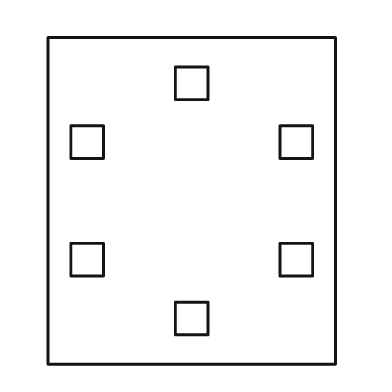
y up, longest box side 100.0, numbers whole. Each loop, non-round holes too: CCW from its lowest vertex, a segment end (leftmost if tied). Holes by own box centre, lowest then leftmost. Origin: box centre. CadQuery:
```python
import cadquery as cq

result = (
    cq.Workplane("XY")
    .moveTo(-44.0, -50.0)
    .lineTo(44.0, -50.0)
    .lineTo(44.0, 50.0)
    .lineTo(-44.0, 50.0)
    .close()
    .moveTo(-5.0, -41.0)
    .lineTo(5.0, -41.0)
    .lineTo(5.0, -31.0)
    .lineTo(-5.0, -31.0)
    .close()
    .moveTo(-37.0, -23.0)
    .lineTo(-27.0, -23.0)
    .lineTo(-27.0, -13.0)
    .lineTo(-37.0, -13.0)
    .close()
    .moveTo(27.0, -23.0)
    .lineTo(37.0, -23.0)
    .lineTo(37.0, -13.0)
    .lineTo(27.0, -13.0)
    .close()
    .moveTo(-37.0, 13.0)
    .lineTo(-27.0, 13.0)
    .lineTo(-27.0, 23.0)
    .lineTo(-37.0, 23.0)
    .close()
    .moveTo(27.0, 13.0)
    .lineTo(37.0, 13.0)
    .lineTo(37.0, 23.0)
    .lineTo(27.0, 23.0)
    .close()
    .moveTo(-5.0, 31.0)
    .lineTo(5.0, 31.0)
    .lineTo(5.0, 41.0)
    .lineTo(-5.0, 41.0)
    .close()
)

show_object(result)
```